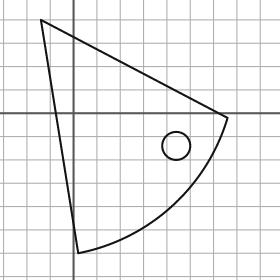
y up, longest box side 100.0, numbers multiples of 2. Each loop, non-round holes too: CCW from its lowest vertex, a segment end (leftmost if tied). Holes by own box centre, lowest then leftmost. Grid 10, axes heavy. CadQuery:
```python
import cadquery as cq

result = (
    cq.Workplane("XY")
    .moveTo(2.0, -60.0)
    .threePointArc((42.0, -40.0), (66.0, -2.0))
    .lineTo(-14.0, 40.0)
    .close()
    .moveTo(44.0, -14.0)
    .circle(6.0)
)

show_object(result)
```